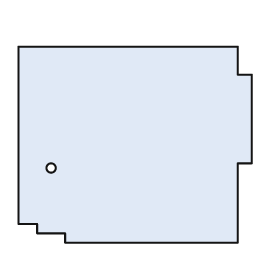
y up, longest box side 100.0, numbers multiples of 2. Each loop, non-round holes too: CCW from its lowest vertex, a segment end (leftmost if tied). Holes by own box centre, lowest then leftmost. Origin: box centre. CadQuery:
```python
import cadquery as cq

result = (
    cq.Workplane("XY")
    .moveTo(-30.0, -42.0)
    .lineTo(44.0, -42.0)
    .lineTo(44.0, -8.0)
    .lineTo(50.0, -8.0)
    .lineTo(50.0, 30.0)
    .lineTo(44.0, 30.0)
    .lineTo(44.0, 42.0)
    .lineTo(-50.0, 42.0)
    .lineTo(-50.0, -34.0)
    .lineTo(-42.0, -34.0)
    .lineTo(-42.0, -38.0)
    .lineTo(-30.0, -38.0)
    .close()
    .moveTo(-36.0, -10.0)
    .circle(2.0)
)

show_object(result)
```